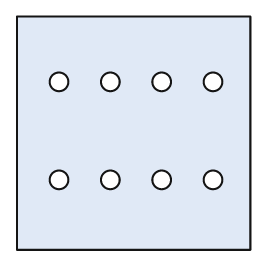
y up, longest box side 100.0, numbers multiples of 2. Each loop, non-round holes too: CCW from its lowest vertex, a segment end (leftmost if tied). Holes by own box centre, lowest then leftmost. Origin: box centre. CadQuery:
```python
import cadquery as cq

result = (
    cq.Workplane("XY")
    .moveTo(-50.0, -50.0)
    .lineTo(50.0, -50.0)
    .lineTo(50.0, 50.0)
    .lineTo(-50.0, 50.0)
    .close()
    .moveTo(-32.0, -20.0)
    .circle(4.0)
    .moveTo(-10.0, -20.0)
    .circle(4.0)
    .moveTo(12.0, -20.0)
    .circle(4.0)
    .moveTo(34.0, -20.0)
    .circle(4.0)
    .moveTo(-32.0, 22.0)
    .circle(4.0)
    .moveTo(-10.0, 22.0)
    .circle(4.0)
    .moveTo(12.0, 22.0)
    .circle(4.0)
    .moveTo(34.0, 22.0)
    .circle(4.0)
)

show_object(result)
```